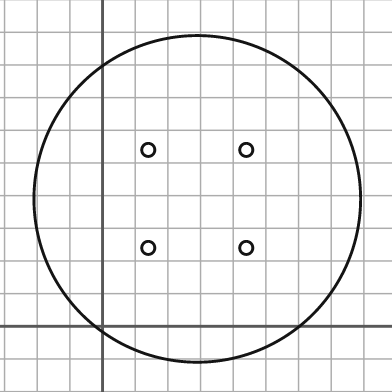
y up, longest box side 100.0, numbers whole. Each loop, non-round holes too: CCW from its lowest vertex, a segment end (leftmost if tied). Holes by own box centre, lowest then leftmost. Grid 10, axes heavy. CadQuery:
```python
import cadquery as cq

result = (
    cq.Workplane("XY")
    .moveTo(29.0, 39.0)
    .circle(50.0)
    .moveTo(14.0, 24.0)
    .circle(2.0)
    .moveTo(44.0, 24.0)
    .circle(2.0)
    .moveTo(14.0, 54.0)
    .circle(2.0)
    .moveTo(44.0, 54.0)
    .circle(2.0)
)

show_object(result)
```